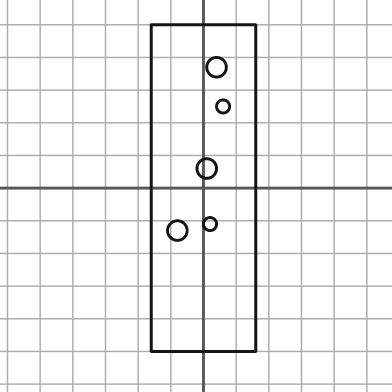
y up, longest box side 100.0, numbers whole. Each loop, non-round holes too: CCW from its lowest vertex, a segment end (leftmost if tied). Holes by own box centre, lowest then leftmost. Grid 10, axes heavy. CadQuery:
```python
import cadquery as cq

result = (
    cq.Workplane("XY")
    .moveTo(-16.0, -50.0)
    .lineTo(16.0, -50.0)
    .lineTo(16.0, 50.0)
    .lineTo(-16.0, 50.0)
    .close()
    .moveTo(-8.0, -13.0)
    .circle(3.0)
    .moveTo(2.0, -11.0)
    .circle(2.0)
    .moveTo(1.0, 6.0)
    .circle(3.0)
    .moveTo(6.0, 25.0)
    .circle(2.0)
    .moveTo(4.0, 37.0)
    .circle(3.0)
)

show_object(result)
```